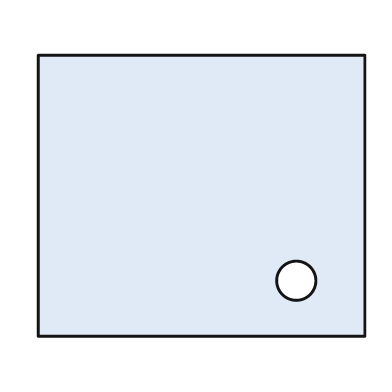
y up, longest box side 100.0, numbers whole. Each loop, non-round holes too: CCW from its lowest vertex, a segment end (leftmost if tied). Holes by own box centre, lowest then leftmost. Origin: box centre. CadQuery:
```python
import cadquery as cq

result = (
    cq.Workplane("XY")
    .moveTo(-50.0, -43.0)
    .lineTo(50.0, -43.0)
    .lineTo(50.0, 43.0)
    .lineTo(-50.0, 43.0)
    .close()
    .moveTo(29.0, -26.0)
    .circle(6.0)
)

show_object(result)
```